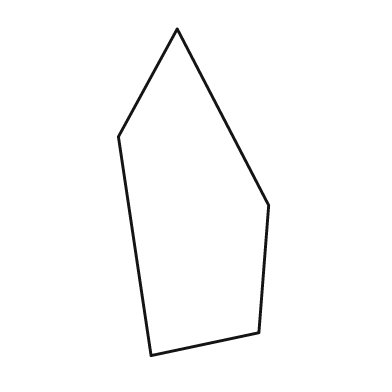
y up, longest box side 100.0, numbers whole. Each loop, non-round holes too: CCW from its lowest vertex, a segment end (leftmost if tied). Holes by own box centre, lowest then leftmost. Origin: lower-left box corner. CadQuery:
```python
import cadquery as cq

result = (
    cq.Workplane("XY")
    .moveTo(10.0, 0.0)
    .lineTo(43.0, 7.0)
    .lineTo(46.0, 46.0)
    .lineTo(18.0, 100.0)
    .lineTo(0.0, 67.0)
    .close()
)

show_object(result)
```